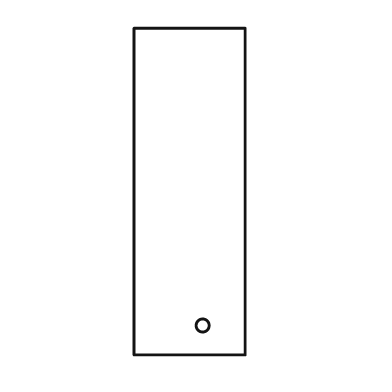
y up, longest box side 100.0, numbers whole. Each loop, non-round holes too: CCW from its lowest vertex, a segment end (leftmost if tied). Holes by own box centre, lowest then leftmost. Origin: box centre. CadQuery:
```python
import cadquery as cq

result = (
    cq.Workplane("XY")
    .moveTo(-17.0, -50.0)
    .lineTo(17.0, -50.0)
    .lineTo(17.0, 50.0)
    .lineTo(-17.0, 50.0)
    .close()
    .moveTo(4.0, -41.0)
    .circle(2.0)
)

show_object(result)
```